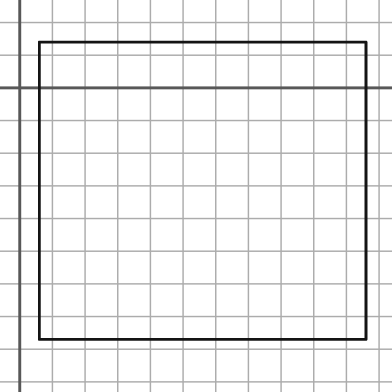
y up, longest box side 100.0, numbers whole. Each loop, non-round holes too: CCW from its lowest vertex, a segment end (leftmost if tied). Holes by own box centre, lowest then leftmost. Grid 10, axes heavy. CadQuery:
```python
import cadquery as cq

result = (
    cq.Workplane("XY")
    .moveTo(6.0, -77.0)
    .lineTo(106.0, -77.0)
    .lineTo(106.0, 14.0)
    .lineTo(6.0, 14.0)
    .close()
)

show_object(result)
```